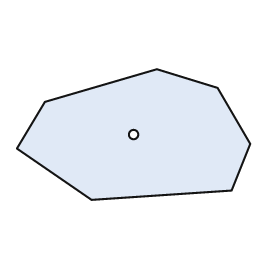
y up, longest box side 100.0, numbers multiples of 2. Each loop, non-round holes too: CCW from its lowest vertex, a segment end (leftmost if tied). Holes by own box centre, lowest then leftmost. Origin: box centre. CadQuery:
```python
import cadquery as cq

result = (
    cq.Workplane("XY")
    .moveTo(-18.0, -28.0)
    .lineTo(42.0, -24.0)
    .lineTo(50.0, -4.0)
    .lineTo(36.0, 20.0)
    .lineTo(10.0, 28.0)
    .lineTo(-38.0, 14.0)
    .lineTo(-50.0, -6.0)
    .close()
    .moveTo(0.0, 0.0)
    .circle(2.0)
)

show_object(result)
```